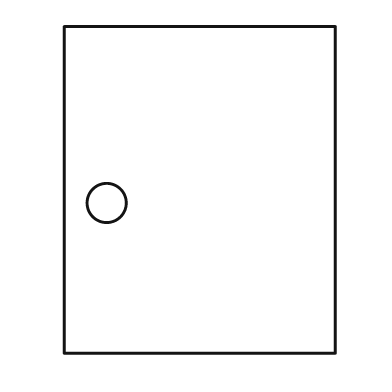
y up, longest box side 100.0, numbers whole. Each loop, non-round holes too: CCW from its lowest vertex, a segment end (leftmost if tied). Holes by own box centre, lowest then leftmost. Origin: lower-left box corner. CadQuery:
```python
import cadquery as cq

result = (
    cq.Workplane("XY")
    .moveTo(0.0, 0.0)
    .lineTo(83.0, 0.0)
    .lineTo(83.0, 100.0)
    .lineTo(0.0, 100.0)
    .close()
    .moveTo(13.0, 46.0)
    .circle(6.0)
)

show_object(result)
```